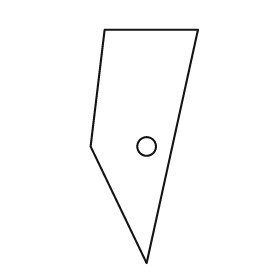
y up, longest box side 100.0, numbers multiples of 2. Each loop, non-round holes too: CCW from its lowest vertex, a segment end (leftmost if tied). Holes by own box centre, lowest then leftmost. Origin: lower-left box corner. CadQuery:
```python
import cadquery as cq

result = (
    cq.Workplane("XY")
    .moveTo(24.0, 0.0)
    .lineTo(46.0, 100.0)
    .lineTo(6.0, 100.0)
    .lineTo(0.0, 50.0)
    .close()
    .moveTo(24.0, 50.0)
    .circle(4.0)
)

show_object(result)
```